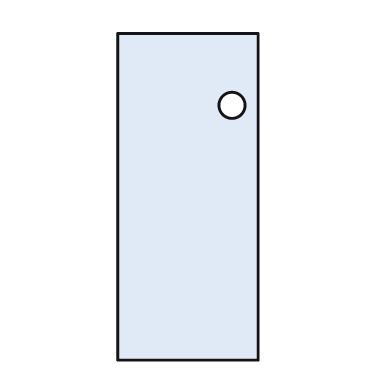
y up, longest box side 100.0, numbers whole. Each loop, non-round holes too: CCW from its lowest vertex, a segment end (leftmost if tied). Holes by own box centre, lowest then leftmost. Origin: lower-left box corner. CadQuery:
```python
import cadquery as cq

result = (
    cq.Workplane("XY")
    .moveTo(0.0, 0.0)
    .lineTo(43.0, 0.0)
    .lineTo(43.0, 100.0)
    .lineTo(0.0, 100.0)
    .close()
    .moveTo(35.0, 78.0)
    .circle(4.0)
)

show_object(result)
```